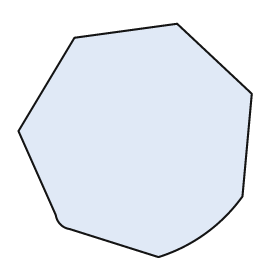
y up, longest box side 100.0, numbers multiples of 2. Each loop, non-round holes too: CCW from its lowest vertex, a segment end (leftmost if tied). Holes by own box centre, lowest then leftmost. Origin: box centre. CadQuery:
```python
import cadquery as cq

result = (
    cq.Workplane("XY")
    .moveTo(10.0, -50.0)
    .threePointArc((30.0, -40.0), (46.0, -24.0))
    .lineTo(50.0, 20.0)
    .lineTo(18.0, 50.0)
    .lineTo(-26.0, 44.0)
    .lineTo(-50.0, 4.0)
    .lineTo(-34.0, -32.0)
    .threePointArc((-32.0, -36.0), (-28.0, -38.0))
    .close()
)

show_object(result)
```